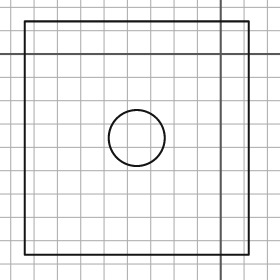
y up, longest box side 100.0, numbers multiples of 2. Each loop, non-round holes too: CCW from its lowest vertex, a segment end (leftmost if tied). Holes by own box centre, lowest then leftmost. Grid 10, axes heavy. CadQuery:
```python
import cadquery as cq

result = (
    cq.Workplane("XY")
    .moveTo(-84.0, -86.0)
    .lineTo(12.0, -86.0)
    .lineTo(12.0, 14.0)
    .lineTo(-84.0, 14.0)
    .close()
    .moveTo(-36.0, -36.0)
    .circle(12.0)
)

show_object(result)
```